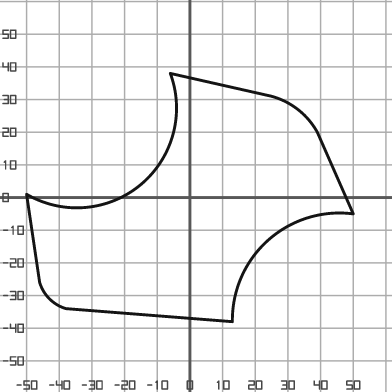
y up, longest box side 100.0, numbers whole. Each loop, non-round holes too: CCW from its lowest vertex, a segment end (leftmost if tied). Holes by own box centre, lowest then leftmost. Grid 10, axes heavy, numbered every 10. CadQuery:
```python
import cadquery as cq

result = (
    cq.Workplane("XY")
    .moveTo(13.0, -38.0)
    .threePointArc((24.0, -13.0), (50.0, -5.0))
    .lineTo(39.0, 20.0)
    .threePointArc((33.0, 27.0), (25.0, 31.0))
    .lineTo(-6.0, 38.0)
    .threePointArc((-15.0, 4.0), (-50.0, 1.0))
    .lineTo(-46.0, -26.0)
    .threePointArc((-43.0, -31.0), (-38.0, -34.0))
    .close()
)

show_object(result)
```